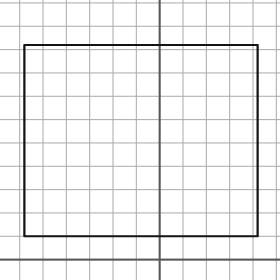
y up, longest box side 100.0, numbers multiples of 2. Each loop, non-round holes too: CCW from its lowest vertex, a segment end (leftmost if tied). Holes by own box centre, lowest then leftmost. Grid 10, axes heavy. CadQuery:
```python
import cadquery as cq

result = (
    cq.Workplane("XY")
    .moveTo(-58.0, 10.0)
    .lineTo(42.0, 10.0)
    .lineTo(42.0, 92.0)
    .lineTo(-58.0, 92.0)
    .close()
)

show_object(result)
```